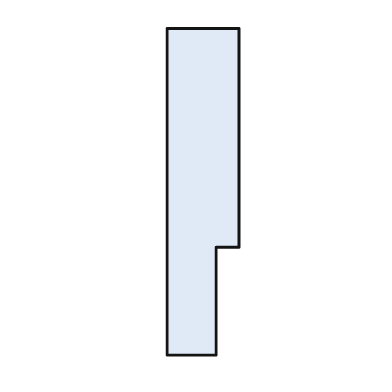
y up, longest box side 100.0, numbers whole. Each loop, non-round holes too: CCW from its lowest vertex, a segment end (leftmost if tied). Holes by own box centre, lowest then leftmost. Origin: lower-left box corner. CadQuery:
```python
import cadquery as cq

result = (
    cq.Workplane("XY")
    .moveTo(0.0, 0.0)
    .lineTo(15.0, 0.0)
    .lineTo(15.0, 33.0)
    .lineTo(22.0, 33.0)
    .lineTo(22.0, 100.0)
    .lineTo(0.0, 100.0)
    .close()
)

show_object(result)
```